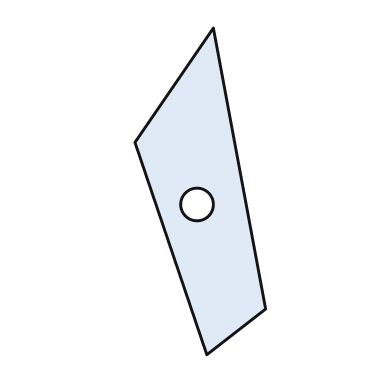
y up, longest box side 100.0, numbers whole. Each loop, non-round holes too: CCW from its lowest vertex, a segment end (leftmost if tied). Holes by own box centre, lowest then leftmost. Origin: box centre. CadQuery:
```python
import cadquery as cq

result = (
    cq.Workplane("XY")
    .moveTo(2.0, -50.0)
    .lineTo(20.0, -36.0)
    .lineTo(4.0, 50.0)
    .lineTo(-20.0, 15.0)
    .close()
    .moveTo(-1.0, -4.0)
    .circle(5.0)
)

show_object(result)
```